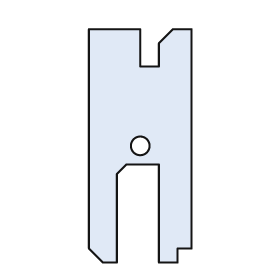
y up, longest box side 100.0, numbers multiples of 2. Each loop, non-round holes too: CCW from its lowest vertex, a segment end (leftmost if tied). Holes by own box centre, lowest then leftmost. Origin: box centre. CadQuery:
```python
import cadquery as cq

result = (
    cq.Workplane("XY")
    .moveTo(-16.0, -50.0)
    .lineTo(-10.0, -50.0)
    .lineTo(-10.0, -12.0)
    .lineTo(-6.0, -8.0)
    .lineTo(8.0, -8.0)
    .lineTo(8.0, -50.0)
    .lineTo(16.0, -50.0)
    .lineTo(16.0, -44.0)
    .lineTo(22.0, -44.0)
    .lineTo(22.0, 50.0)
    .lineTo(14.0, 50.0)
    .lineTo(8.0, 44.0)
    .lineTo(8.0, 34.0)
    .lineTo(0.0, 34.0)
    .lineTo(0.0, 50.0)
    .lineTo(-22.0, 50.0)
    .lineTo(-22.0, -44.0)
    .close()
    .moveTo(0.0, 0.0)
    .circle(4.0)
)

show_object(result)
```